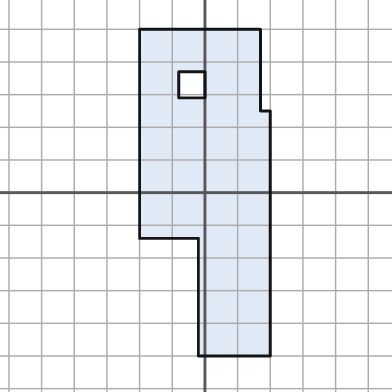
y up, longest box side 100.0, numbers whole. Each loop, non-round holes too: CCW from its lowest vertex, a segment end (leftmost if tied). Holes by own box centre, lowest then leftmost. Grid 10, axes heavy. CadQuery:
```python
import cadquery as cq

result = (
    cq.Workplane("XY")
    .moveTo(-2.0, -50.0)
    .lineTo(20.0, -50.0)
    .lineTo(20.0, 25.0)
    .lineTo(17.0, 25.0)
    .lineTo(17.0, 50.0)
    .lineTo(-20.0, 50.0)
    .lineTo(-20.0, -14.0)
    .lineTo(-2.0, -14.0)
    .close()
    .moveTo(-8.0, 29.0)
    .lineTo(0.0, 29.0)
    .lineTo(0.0, 37.0)
    .lineTo(-8.0, 37.0)
    .close()
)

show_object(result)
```